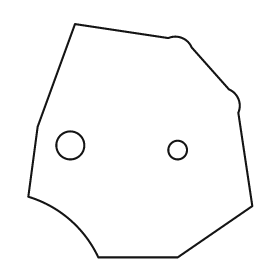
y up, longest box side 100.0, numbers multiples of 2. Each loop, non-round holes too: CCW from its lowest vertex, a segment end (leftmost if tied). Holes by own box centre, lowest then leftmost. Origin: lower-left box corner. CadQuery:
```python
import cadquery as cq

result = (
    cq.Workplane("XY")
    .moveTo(30.0, 0.0)
    .lineTo(64.0, 0.0)
    .lineTo(96.0, 22.0)
    .lineTo(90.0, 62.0)
    .threePointArc((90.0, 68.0), (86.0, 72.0))
    .lineTo(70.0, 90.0)
    .threePointArc((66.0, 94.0), (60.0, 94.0))
    .lineTo(20.0, 100.0)
    .lineTo(4.0, 56.0)
    .lineTo(0.0, 26.0)
    .threePointArc((18.0, 16.0), (30.0, 0.0))
    .close()
    .moveTo(64.0, 46.0)
    .circle(4.0)
    .moveTo(18.0, 48.0)
    .circle(6.0)
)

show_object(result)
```